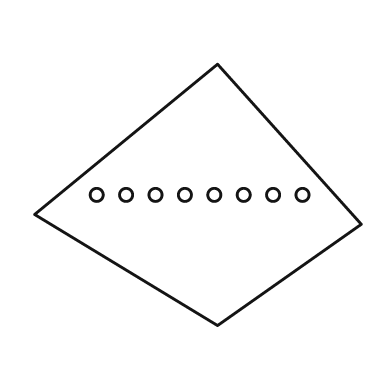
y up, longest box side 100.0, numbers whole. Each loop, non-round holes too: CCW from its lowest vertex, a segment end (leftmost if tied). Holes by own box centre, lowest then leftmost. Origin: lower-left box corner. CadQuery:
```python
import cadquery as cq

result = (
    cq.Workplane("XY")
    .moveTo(56.0, 0.0)
    .lineTo(100.0, 31.0)
    .lineTo(56.0, 80.0)
    .lineTo(0.0, 34.0)
    .close()
    .moveTo(19.0, 40.0)
    .circle(2.0)
    .moveTo(28.0, 40.0)
    .circle(2.0)
    .moveTo(37.0, 40.0)
    .circle(2.0)
    .moveTo(46.0, 40.0)
    .circle(2.0)
    .moveTo(55.0, 40.0)
    .circle(2.0)
    .moveTo(64.0, 40.0)
    .circle(2.0)
    .moveTo(73.0, 40.0)
    .circle(2.0)
    .moveTo(82.0, 40.0)
    .circle(2.0)
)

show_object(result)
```